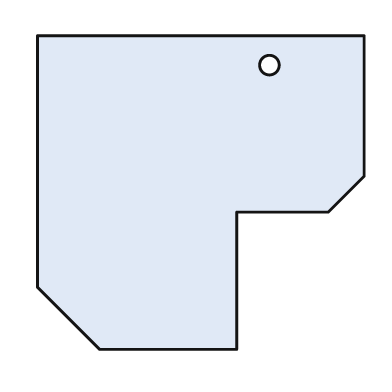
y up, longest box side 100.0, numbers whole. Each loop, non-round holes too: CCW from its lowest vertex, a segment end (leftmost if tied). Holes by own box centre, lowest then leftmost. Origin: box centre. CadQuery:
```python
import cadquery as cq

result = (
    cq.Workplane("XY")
    .moveTo(-31.0, -48.0)
    .lineTo(11.0, -48.0)
    .lineTo(11.0, -6.0)
    .lineTo(39.0, -6.0)
    .lineTo(50.0, 5.0)
    .lineTo(50.0, 48.0)
    .lineTo(-50.0, 48.0)
    .lineTo(-50.0, -29.0)
    .close()
    .moveTo(21.0, 39.0)
    .circle(3.0)
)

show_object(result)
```